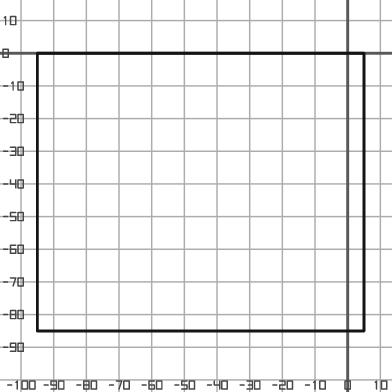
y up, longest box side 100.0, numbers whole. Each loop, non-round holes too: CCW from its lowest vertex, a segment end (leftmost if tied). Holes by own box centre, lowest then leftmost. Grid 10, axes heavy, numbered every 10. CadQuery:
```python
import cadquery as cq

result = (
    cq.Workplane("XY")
    .moveTo(-95.0, -85.0)
    .lineTo(5.0, -85.0)
    .lineTo(5.0, 0.0)
    .lineTo(-95.0, 0.0)
    .close()
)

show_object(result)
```